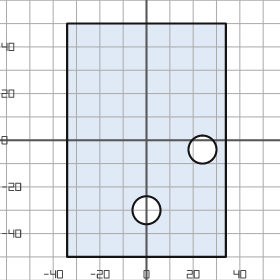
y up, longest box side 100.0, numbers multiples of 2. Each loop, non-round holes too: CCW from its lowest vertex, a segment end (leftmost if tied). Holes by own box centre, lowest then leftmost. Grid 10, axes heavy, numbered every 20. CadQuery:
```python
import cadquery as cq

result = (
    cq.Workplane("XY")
    .moveTo(-34.0, -50.0)
    .lineTo(34.0, -50.0)
    .lineTo(34.0, 50.0)
    .lineTo(-34.0, 50.0)
    .close()
    .moveTo(0.0, -30.0)
    .circle(6.0)
    .moveTo(24.0, -4.0)
    .circle(6.0)
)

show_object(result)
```